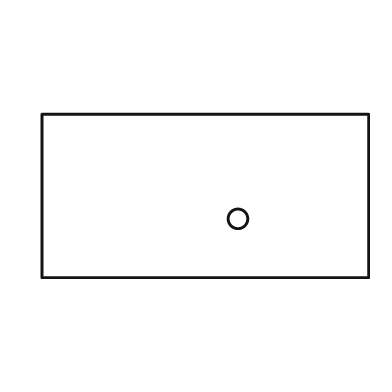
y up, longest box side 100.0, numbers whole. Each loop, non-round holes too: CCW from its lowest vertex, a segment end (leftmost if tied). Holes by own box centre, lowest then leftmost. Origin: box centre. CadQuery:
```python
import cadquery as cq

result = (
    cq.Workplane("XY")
    .moveTo(-50.0, -25.0)
    .lineTo(50.0, -25.0)
    .lineTo(50.0, 25.0)
    .lineTo(-50.0, 25.0)
    .close()
    .moveTo(10.0, -7.0)
    .circle(3.0)
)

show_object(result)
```